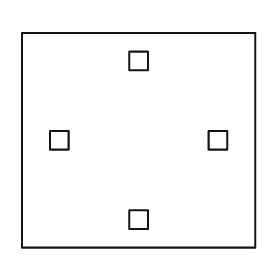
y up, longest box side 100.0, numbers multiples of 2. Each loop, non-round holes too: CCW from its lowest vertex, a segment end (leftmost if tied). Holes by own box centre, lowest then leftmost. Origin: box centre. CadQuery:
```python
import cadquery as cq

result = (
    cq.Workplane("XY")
    .moveTo(-50.0, -46.0)
    .lineTo(50.0, -46.0)
    .lineTo(50.0, 46.0)
    .lineTo(-50.0, 46.0)
    .close()
    .moveTo(-4.0, -38.0)
    .lineTo(4.0, -38.0)
    .lineTo(4.0, -30.0)
    .lineTo(-4.0, -30.0)
    .close()
    .moveTo(-38.0, -4.0)
    .lineTo(-30.0, -4.0)
    .lineTo(-30.0, 4.0)
    .lineTo(-38.0, 4.0)
    .close()
    .moveTo(30.0, -4.0)
    .lineTo(38.0, -4.0)
    .lineTo(38.0, 4.0)
    .lineTo(30.0, 4.0)
    .close()
    .moveTo(-4.0, 30.0)
    .lineTo(4.0, 30.0)
    .lineTo(4.0, 38.0)
    .lineTo(-4.0, 38.0)
    .close()
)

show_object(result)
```